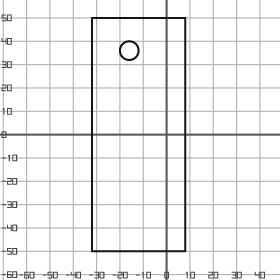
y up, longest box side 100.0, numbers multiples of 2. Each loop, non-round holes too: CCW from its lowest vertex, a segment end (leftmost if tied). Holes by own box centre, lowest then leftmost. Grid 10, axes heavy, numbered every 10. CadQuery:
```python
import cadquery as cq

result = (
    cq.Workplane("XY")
    .moveTo(-32.0, -50.0)
    .lineTo(8.0, -50.0)
    .lineTo(8.0, 50.0)
    .lineTo(-32.0, 50.0)
    .close()
    .moveTo(-16.0, 36.0)
    .circle(4.0)
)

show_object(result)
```